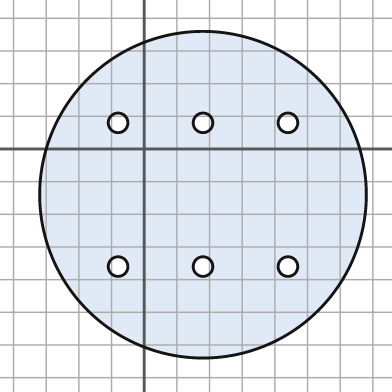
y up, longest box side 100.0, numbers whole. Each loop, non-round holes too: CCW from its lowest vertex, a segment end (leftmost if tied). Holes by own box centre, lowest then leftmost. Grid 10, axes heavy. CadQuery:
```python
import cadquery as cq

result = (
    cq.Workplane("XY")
    .moveTo(18.0, -14.0)
    .circle(50.0)
    .moveTo(-8.0, -36.0)
    .circle(3.0)
    .moveTo(18.0, -36.0)
    .circle(3.0)
    .moveTo(44.0, -36.0)
    .circle(3.0)
    .moveTo(-8.0, 8.0)
    .circle(3.0)
    .moveTo(18.0, 8.0)
    .circle(3.0)
    .moveTo(44.0, 8.0)
    .circle(3.0)
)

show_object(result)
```